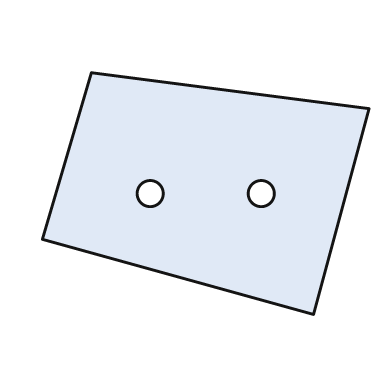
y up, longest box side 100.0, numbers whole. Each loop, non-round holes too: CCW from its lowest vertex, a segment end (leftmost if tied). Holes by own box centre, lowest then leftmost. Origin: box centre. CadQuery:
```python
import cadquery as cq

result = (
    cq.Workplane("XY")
    .moveTo(33.0, -37.0)
    .lineTo(50.0, 26.0)
    .lineTo(-35.0, 37.0)
    .lineTo(-50.0, -14.0)
    .close()
    .moveTo(-17.0, 0.0)
    .circle(4.0)
    .moveTo(17.0, 0.0)
    .circle(4.0)
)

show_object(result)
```